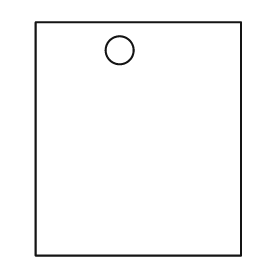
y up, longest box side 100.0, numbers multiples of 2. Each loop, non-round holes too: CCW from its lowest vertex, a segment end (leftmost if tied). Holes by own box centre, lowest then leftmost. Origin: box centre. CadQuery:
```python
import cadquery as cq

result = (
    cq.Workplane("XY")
    .moveTo(-44.0, -50.0)
    .lineTo(44.0, -50.0)
    .lineTo(44.0, 50.0)
    .lineTo(-44.0, 50.0)
    .close()
    .moveTo(-8.0, 38.0)
    .circle(6.0)
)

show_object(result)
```